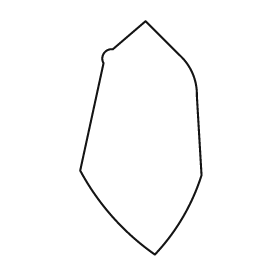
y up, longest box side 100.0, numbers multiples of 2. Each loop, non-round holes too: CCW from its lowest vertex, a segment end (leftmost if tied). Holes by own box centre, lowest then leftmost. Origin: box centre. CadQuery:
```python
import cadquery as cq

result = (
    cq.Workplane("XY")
    .moveTo(6.0, -50.0)
    .threePointArc((18.0, -34.0), (26.0, -16.0))
    .lineTo(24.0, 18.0)
    .threePointArc((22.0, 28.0), (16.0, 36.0))
    .lineTo(2.0, 50.0)
    .lineTo(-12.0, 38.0)
    .threePointArc((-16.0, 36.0), (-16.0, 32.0))
    .lineTo(-26.0, -14.0)
    .threePointArc((-12.0, -34.0), (6.0, -50.0))
    .close()
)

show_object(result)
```